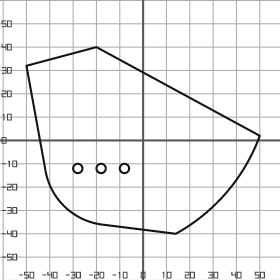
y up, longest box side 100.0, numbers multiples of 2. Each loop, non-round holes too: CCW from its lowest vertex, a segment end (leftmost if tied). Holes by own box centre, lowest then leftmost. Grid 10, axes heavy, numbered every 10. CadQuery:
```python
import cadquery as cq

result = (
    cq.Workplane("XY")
    .moveTo(14.0, -40.0)
    .threePointArc((36.0, -22.0), (50.0, 2.0))
    .lineTo(-20.0, 40.0)
    .lineTo(-50.0, 32.0)
    .lineTo(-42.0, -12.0)
    .threePointArc((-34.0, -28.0), (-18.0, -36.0))
    .close()
    .moveTo(-28.0, -12.0)
    .circle(2.0)
    .moveTo(-18.0, -12.0)
    .circle(2.0)
    .moveTo(-8.0, -12.0)
    .circle(2.0)
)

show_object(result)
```